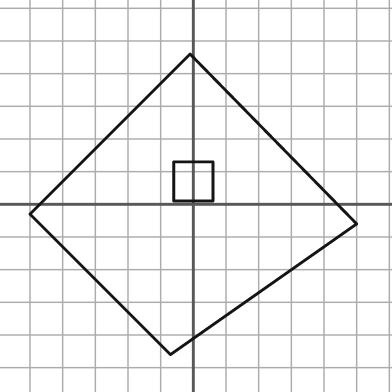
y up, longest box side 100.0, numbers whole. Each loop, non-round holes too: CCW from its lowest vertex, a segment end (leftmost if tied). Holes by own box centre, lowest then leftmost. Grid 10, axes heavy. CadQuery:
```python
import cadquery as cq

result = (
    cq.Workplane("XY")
    .moveTo(-7.0, -46.0)
    .lineTo(50.0, -6.0)
    .lineTo(-1.0, 46.0)
    .lineTo(-50.0, -3.0)
    .close()
    .moveTo(-6.0, 1.0)
    .lineTo(6.0, 1.0)
    .lineTo(6.0, 13.0)
    .lineTo(-6.0, 13.0)
    .close()
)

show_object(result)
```